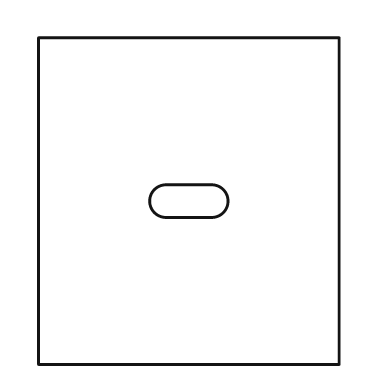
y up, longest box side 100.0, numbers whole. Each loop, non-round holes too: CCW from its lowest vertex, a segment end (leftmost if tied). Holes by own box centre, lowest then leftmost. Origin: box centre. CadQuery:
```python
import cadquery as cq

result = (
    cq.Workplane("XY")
    .moveTo(-46.0, -50.0)
    .lineTo(46.0, -50.0)
    .lineTo(46.0, 50.0)
    .lineTo(-46.0, 50.0)
    .close()
    .moveTo(-7.0, -5.0)
    .lineTo(7.0, -5.0)
    .threePointArc((12.0, 0.0), (7.0, 5.0))
    .lineTo(-7.0, 5.0)
    .threePointArc((-12.0, 0.0), (-7.0, -5.0))
    .close()
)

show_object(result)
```